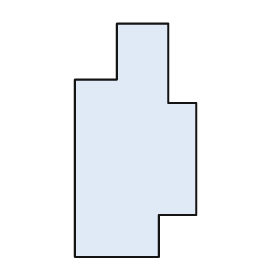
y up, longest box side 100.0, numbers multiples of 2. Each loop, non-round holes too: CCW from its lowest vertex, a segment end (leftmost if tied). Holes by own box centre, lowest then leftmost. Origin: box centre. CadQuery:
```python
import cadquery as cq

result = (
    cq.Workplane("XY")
    .moveTo(-26.0, -50.0)
    .lineTo(10.0, -50.0)
    .lineTo(10.0, -32.0)
    .lineTo(26.0, -32.0)
    .lineTo(26.0, 16.0)
    .lineTo(14.0, 16.0)
    .lineTo(14.0, 50.0)
    .lineTo(-8.0, 50.0)
    .lineTo(-8.0, 26.0)
    .lineTo(-26.0, 26.0)
    .close()
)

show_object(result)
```